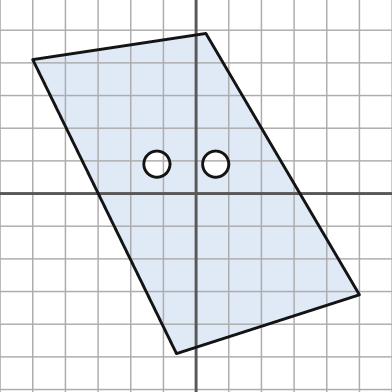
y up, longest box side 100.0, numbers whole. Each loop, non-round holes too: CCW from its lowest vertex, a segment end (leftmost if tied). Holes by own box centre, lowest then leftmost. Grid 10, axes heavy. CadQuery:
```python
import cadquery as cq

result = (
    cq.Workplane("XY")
    .moveTo(-6.0, -49.0)
    .lineTo(50.0, -31.0)
    .lineTo(3.0, 49.0)
    .lineTo(-50.0, 41.0)
    .close()
    .moveTo(-12.0, 9.0)
    .circle(4.0)
    .moveTo(6.0, 9.0)
    .circle(4.0)
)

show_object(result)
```